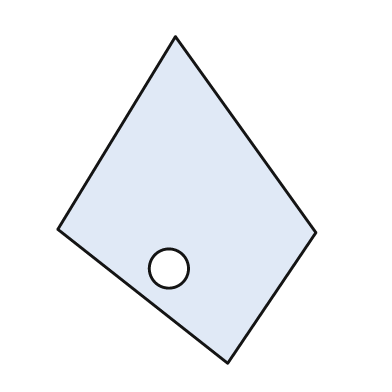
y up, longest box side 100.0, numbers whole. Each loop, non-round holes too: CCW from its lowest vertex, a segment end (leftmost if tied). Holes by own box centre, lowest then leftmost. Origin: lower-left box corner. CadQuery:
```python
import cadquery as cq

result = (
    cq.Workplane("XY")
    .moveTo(52.0, 0.0)
    .lineTo(79.0, 40.0)
    .lineTo(36.0, 100.0)
    .lineTo(0.0, 41.0)
    .close()
    .moveTo(34.0, 29.0)
    .circle(6.0)
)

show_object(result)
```